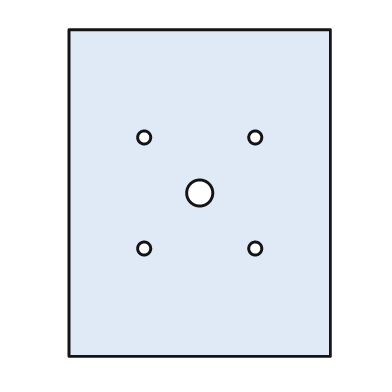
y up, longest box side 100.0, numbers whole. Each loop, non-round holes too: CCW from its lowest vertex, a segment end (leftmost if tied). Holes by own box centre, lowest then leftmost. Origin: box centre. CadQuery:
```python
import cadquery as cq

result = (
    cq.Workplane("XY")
    .moveTo(-40.0, -50.0)
    .lineTo(40.0, -50.0)
    .lineTo(40.0, 50.0)
    .lineTo(-40.0, 50.0)
    .close()
    .moveTo(-17.0, -17.0)
    .circle(2.0)
    .moveTo(17.0, -17.0)
    .circle(2.0)
    .moveTo(0.0, 0.0)
    .circle(4.0)
    .moveTo(-17.0, 17.0)
    .circle(2.0)
    .moveTo(17.0, 17.0)
    .circle(2.0)
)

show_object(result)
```